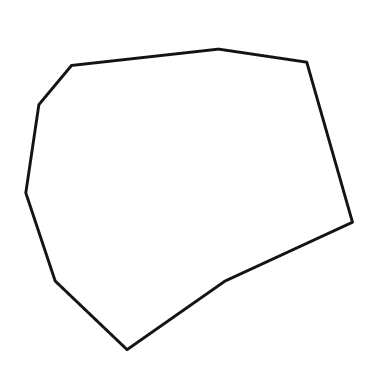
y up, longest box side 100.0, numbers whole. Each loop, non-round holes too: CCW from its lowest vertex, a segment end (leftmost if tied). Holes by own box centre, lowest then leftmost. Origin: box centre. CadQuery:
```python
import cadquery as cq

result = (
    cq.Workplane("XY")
    .moveTo(-19.0, -46.0)
    .lineTo(11.0, -25.0)
    .lineTo(50.0, -7.0)
    .lineTo(36.0, 42.0)
    .lineTo(9.0, 46.0)
    .lineTo(-36.0, 41.0)
    .lineTo(-46.0, 29.0)
    .lineTo(-50.0, 2.0)
    .lineTo(-41.0, -25.0)
    .close()
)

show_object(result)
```